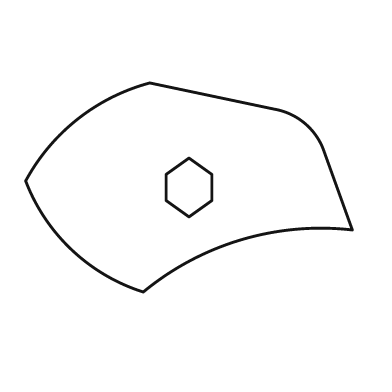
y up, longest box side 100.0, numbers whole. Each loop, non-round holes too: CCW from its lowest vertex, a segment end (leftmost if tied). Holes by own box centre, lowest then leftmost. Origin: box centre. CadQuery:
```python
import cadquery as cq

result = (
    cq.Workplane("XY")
    .moveTo(-14.0, -32.0)
    .threePointArc((16.0, -16.0), (50.0, -13.0))
    .lineTo(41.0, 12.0)
    .threePointArc((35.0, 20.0), (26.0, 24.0))
    .lineTo(-12.0, 32.0)
    .threePointArc((-34.0, 21.0), (-50.0, 2.0))
    .threePointArc((-36.0, -19.0), (-14.0, -32.0))
    .close()
    .moveTo(0.0, -9.0)
    .lineTo(7.0, -4.0)
    .lineTo(7.0, 4.0)
    .lineTo(0.0, 9.0)
    .lineTo(-7.0, 4.0)
    .lineTo(-7.0, -4.0)
    .close()
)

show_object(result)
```